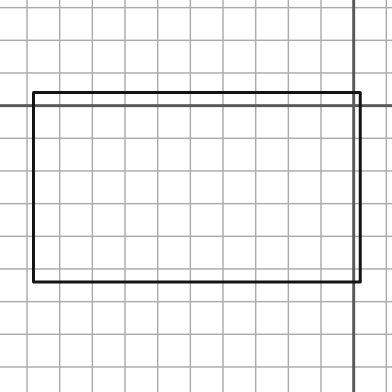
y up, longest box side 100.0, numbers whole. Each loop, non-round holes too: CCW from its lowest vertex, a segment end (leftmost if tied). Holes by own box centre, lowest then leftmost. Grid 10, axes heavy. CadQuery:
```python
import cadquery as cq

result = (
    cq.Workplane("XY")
    .moveTo(-98.0, -54.0)
    .lineTo(2.0, -54.0)
    .lineTo(2.0, 4.0)
    .lineTo(-98.0, 4.0)
    .close()
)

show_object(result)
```